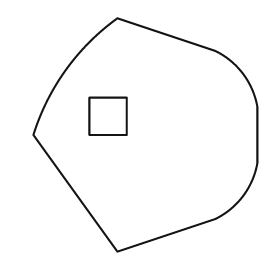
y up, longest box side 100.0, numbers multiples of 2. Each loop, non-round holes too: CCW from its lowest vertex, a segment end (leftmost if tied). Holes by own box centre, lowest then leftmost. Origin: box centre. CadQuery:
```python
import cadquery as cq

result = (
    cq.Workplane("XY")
    .moveTo(-12.0, -50.0)
    .lineTo(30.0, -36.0)
    .threePointArc((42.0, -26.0), (48.0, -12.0))
    .lineTo(48.0, 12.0)
    .threePointArc((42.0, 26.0), (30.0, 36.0))
    .lineTo(-12.0, 50.0)
    .threePointArc((-34.0, 28.0), (-48.0, 0.0))
    .close()
    .moveTo(-24.0, 0.0)
    .lineTo(-8.0, 0.0)
    .lineTo(-8.0, 16.0)
    .lineTo(-24.0, 16.0)
    .close()
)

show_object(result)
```